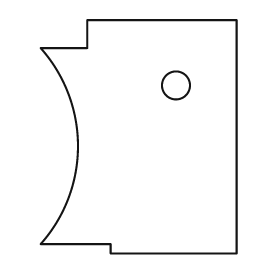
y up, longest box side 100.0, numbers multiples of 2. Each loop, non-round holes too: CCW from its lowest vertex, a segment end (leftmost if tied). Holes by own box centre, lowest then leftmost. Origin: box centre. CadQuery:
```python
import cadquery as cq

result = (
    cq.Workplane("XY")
    .moveTo(-12.0, -50.0)
    .lineTo(42.0, -50.0)
    .lineTo(42.0, 50.0)
    .lineTo(-22.0, 50.0)
    .lineTo(-22.0, 38.0)
    .lineTo(-42.0, 38.0)
    .threePointArc((-26.0, -4.0), (-42.0, -46.0))
    .lineTo(-12.0, -46.0)
    .close()
    .moveTo(16.0, 22.0)
    .circle(6.0)
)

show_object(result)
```